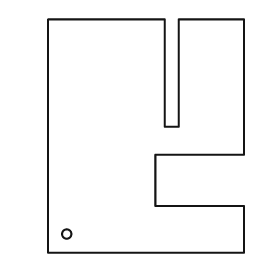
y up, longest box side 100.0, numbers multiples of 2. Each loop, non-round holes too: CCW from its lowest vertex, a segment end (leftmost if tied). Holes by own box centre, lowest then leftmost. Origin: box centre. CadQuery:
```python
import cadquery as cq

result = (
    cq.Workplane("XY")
    .moveTo(-42.0, -50.0)
    .lineTo(42.0, -50.0)
    .lineTo(42.0, -30.0)
    .lineTo(4.0, -30.0)
    .lineTo(4.0, -8.0)
    .lineTo(42.0, -8.0)
    .lineTo(42.0, 50.0)
    .lineTo(14.0, 50.0)
    .lineTo(14.0, 4.0)
    .lineTo(8.0, 4.0)
    .lineTo(8.0, 50.0)
    .lineTo(-42.0, 50.0)
    .close()
    .moveTo(-34.0, -42.0)
    .circle(2.0)
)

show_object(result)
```